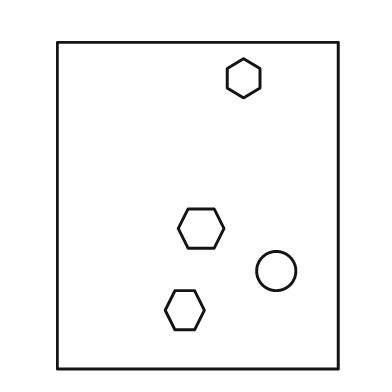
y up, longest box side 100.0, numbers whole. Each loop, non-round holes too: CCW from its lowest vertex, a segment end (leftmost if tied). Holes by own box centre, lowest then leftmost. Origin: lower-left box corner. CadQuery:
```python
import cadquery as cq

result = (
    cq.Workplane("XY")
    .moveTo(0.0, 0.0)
    .lineTo(86.0, 0.0)
    .lineTo(86.0, 100.0)
    .lineTo(0.0, 100.0)
    .close()
    .moveTo(36.0, 12.0)
    .lineTo(42.0, 12.0)
    .lineTo(45.0, 18.0)
    .lineTo(42.0, 24.0)
    .lineTo(36.0, 24.0)
    .lineTo(33.0, 18.0)
    .close()
    .moveTo(67.0, 30.0)
    .circle(6.0)
    .moveTo(40.0, 37.0)
    .lineTo(48.0, 37.0)
    .lineTo(51.0, 43.0)
    .lineTo(48.0, 49.0)
    .lineTo(40.0, 49.0)
    .lineTo(37.0, 43.0)
    .close()
    .moveTo(57.0, 83.0)
    .lineTo(62.0, 86.0)
    .lineTo(62.0, 92.0)
    .lineTo(57.0, 95.0)
    .lineTo(52.0, 92.0)
    .lineTo(52.0, 86.0)
    .close()
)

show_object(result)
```